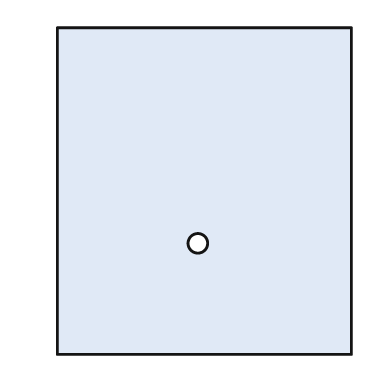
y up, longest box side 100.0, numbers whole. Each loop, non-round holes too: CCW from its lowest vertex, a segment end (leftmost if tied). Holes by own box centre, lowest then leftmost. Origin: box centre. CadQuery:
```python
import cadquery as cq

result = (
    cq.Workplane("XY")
    .moveTo(-45.0, -50.0)
    .lineTo(45.0, -50.0)
    .lineTo(45.0, 50.0)
    .lineTo(-45.0, 50.0)
    .close()
    .moveTo(-2.0, -16.0)
    .circle(3.0)
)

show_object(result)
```